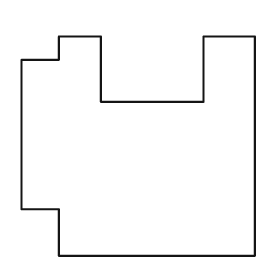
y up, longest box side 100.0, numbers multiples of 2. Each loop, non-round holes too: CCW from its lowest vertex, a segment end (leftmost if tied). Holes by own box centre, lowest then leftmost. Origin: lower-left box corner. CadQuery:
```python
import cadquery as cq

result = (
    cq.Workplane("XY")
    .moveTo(16.0, 0.0)
    .lineTo(100.0, 0.0)
    .lineTo(100.0, 94.0)
    .lineTo(78.0, 94.0)
    .lineTo(78.0, 66.0)
    .lineTo(34.0, 66.0)
    .lineTo(34.0, 94.0)
    .lineTo(16.0, 94.0)
    .lineTo(16.0, 84.0)
    .lineTo(0.0, 84.0)
    .lineTo(0.0, 20.0)
    .lineTo(16.0, 20.0)
    .close()
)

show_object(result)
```